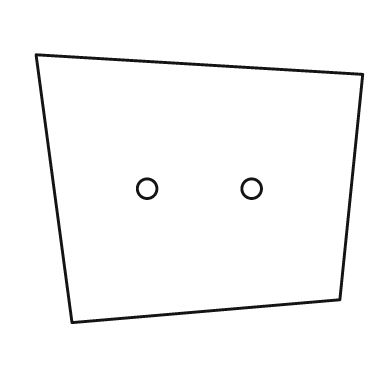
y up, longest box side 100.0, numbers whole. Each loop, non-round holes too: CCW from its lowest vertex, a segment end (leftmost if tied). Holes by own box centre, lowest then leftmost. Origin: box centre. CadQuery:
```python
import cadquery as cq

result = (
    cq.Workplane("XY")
    .moveTo(-39.0, -41.0)
    .lineTo(43.0, -34.0)
    .lineTo(50.0, 35.0)
    .lineTo(-50.0, 41.0)
    .close()
    .moveTo(-16.0, 0.0)
    .circle(3.0)
    .moveTo(16.0, 0.0)
    .circle(3.0)
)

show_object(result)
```